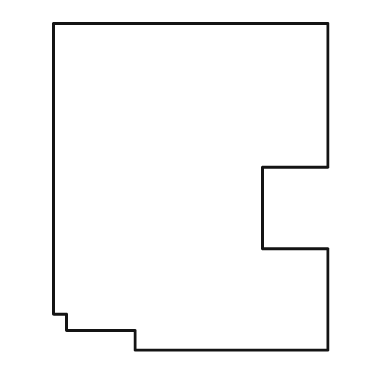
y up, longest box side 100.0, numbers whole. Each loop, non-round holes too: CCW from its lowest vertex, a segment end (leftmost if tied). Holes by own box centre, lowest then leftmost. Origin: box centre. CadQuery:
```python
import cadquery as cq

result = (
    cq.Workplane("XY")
    .moveTo(-17.0, -50.0)
    .lineTo(42.0, -50.0)
    .lineTo(42.0, -19.0)
    .lineTo(22.0, -19.0)
    .lineTo(22.0, 6.0)
    .lineTo(42.0, 6.0)
    .lineTo(42.0, 50.0)
    .lineTo(-42.0, 50.0)
    .lineTo(-42.0, -39.0)
    .lineTo(-38.0, -39.0)
    .lineTo(-38.0, -44.0)
    .lineTo(-17.0, -44.0)
    .close()
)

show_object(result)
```